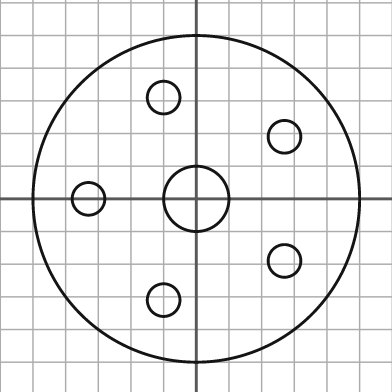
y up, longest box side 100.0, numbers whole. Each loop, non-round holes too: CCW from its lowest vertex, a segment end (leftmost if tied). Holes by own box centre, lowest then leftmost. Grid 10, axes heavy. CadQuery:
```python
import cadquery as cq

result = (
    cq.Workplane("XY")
    .moveTo(0.0, 0.0)
    .circle(50.0)
    .moveTo(-10.0, -31.0)
    .circle(5.0)
    .moveTo(27.0, -19.0)
    .circle(5.0)
    .moveTo(-33.0, 0.0)
    .circle(5.0)
    .moveTo(0.0, 0.0)
    .circle(10.0)
    .moveTo(27.0, 19.0)
    .circle(5.0)
    .moveTo(-10.0, 31.0)
    .circle(5.0)
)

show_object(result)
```